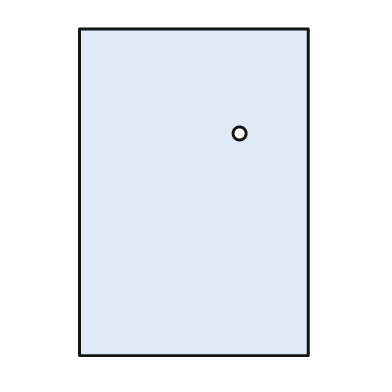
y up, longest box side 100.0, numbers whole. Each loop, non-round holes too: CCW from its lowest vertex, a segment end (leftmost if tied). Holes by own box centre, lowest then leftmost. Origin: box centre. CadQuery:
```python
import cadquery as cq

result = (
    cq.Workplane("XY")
    .moveTo(-35.0, -50.0)
    .lineTo(35.0, -50.0)
    .lineTo(35.0, 50.0)
    .lineTo(-35.0, 50.0)
    .close()
    .moveTo(14.0, 18.0)
    .circle(2.0)
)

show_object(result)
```